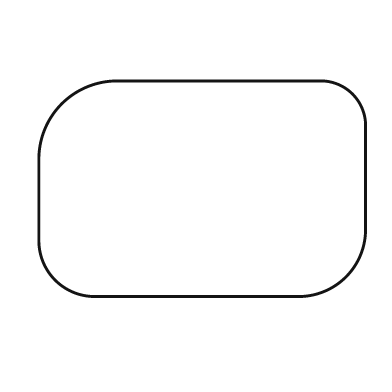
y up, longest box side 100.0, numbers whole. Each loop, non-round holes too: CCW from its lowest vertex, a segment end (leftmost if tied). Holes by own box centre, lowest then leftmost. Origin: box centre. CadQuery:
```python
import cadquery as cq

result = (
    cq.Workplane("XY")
    .moveTo(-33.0, -33.0)
    .lineTo(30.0, -33.0)
    .threePointArc((44.0, -27.0), (50.0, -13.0))
    .lineTo(50.0, 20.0)
    .threePointArc((46.0, 29.0), (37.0, 33.0))
    .lineTo(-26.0, 33.0)
    .threePointArc((-43.0, 26.0), (-50.0, 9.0))
    .lineTo(-50.0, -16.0)
    .threePointArc((-45.0, -28.0), (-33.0, -33.0))
    .close()
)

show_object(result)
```